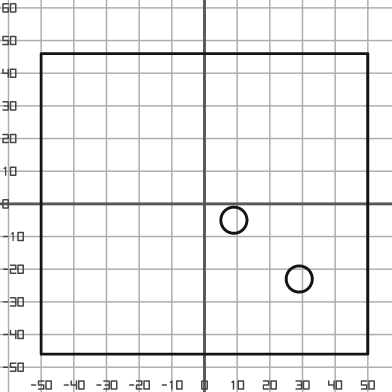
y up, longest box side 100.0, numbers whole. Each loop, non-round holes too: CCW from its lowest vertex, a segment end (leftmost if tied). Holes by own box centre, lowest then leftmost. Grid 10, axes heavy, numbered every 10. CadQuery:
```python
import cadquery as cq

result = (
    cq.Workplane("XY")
    .moveTo(-50.0, -46.0)
    .lineTo(50.0, -46.0)
    .lineTo(50.0, 46.0)
    .lineTo(-50.0, 46.0)
    .close()
    .moveTo(29.0, -23.0)
    .circle(4.0)
    .moveTo(9.0, -5.0)
    .circle(4.0)
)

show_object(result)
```